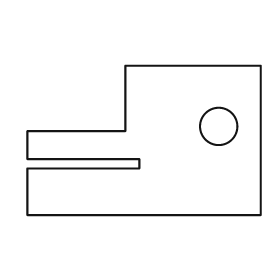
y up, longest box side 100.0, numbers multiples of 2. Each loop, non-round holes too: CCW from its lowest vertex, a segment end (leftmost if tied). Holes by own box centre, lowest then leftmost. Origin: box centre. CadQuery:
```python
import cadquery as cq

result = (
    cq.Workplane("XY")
    .moveTo(-50.0, -32.0)
    .lineTo(50.0, -32.0)
    .lineTo(50.0, 32.0)
    .lineTo(-8.0, 32.0)
    .lineTo(-8.0, 4.0)
    .lineTo(-50.0, 4.0)
    .lineTo(-50.0, -8.0)
    .lineTo(-2.0, -8.0)
    .lineTo(-2.0, -12.0)
    .lineTo(-50.0, -12.0)
    .close()
    .moveTo(32.0, 6.0)
    .circle(8.0)
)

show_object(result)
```